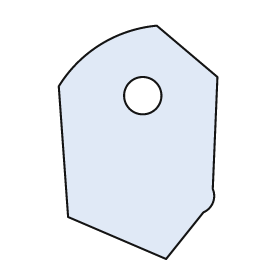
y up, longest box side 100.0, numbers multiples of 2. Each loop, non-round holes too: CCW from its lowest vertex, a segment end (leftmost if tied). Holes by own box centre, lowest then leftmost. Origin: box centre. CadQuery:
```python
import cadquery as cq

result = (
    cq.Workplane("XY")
    .moveTo(12.0, -50.0)
    .lineTo(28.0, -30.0)
    .threePointArc((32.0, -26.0), (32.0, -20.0))
    .lineTo(34.0, 28.0)
    .lineTo(8.0, 50.0)
    .threePointArc((-16.0, 42.0), (-34.0, 24.0))
    .lineTo(-30.0, -32.0)
    .close()
    .moveTo(2.0, 20.0)
    .circle(8.0)
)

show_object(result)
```